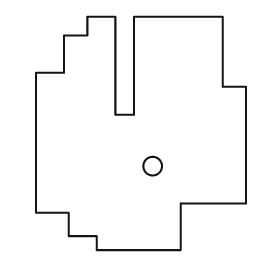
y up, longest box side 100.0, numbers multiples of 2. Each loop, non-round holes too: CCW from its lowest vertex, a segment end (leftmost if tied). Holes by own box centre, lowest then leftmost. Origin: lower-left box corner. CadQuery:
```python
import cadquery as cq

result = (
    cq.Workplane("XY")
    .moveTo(26.0, 0.0)
    .lineTo(62.0, 0.0)
    .lineTo(62.0, 20.0)
    .lineTo(90.0, 20.0)
    .lineTo(90.0, 70.0)
    .lineTo(80.0, 70.0)
    .lineTo(80.0, 100.0)
    .lineTo(42.0, 100.0)
    .lineTo(42.0, 58.0)
    .lineTo(34.0, 58.0)
    .lineTo(34.0, 100.0)
    .lineTo(22.0, 100.0)
    .lineTo(22.0, 92.0)
    .lineTo(12.0, 92.0)
    .lineTo(12.0, 76.0)
    .lineTo(0.0, 76.0)
    .lineTo(0.0, 16.0)
    .lineTo(14.0, 16.0)
    .lineTo(14.0, 6.0)
    .lineTo(26.0, 6.0)
    .close()
    .moveTo(50.0, 36.0)
    .circle(4.0)
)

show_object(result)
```